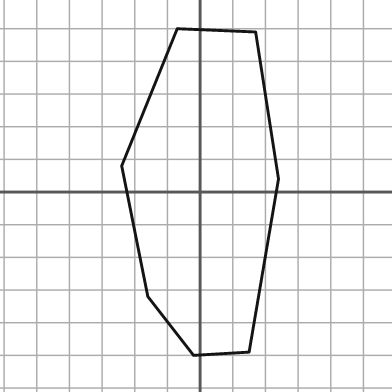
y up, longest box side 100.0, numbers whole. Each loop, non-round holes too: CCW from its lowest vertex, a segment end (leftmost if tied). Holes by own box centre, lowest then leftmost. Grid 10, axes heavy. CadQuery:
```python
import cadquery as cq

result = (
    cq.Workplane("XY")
    .moveTo(-2.0, -50.0)
    .lineTo(15.0, -49.0)
    .lineTo(24.0, 4.0)
    .lineTo(17.0, 49.0)
    .lineTo(-7.0, 50.0)
    .lineTo(-24.0, 8.0)
    .lineTo(-16.0, -32.0)
    .close()
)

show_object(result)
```